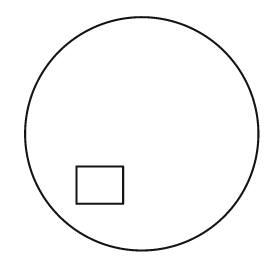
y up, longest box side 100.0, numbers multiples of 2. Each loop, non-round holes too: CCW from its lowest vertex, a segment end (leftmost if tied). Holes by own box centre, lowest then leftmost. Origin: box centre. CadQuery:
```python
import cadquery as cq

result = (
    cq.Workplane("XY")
    .moveTo(0.0, 0.0)
    .circle(50.0)
    .moveTo(-28.0, -30.0)
    .lineTo(-8.0, -30.0)
    .lineTo(-8.0, -14.0)
    .lineTo(-28.0, -14.0)
    .close()
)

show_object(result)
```